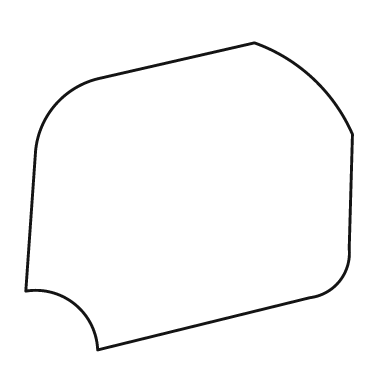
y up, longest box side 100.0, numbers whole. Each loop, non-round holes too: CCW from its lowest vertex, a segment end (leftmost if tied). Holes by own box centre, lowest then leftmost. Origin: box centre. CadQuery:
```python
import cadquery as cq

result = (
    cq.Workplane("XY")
    .moveTo(-28.0, -47.0)
    .lineTo(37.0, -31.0)
    .threePointArc((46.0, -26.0), (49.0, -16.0))
    .lineTo(50.0, 19.0)
    .threePointArc((38.0, 36.0), (20.0, 47.0))
    .lineTo(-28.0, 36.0)
    .threePointArc((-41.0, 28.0), (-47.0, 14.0))
    .lineTo(-50.0, -29.0)
    .threePointArc((-35.0, -33.0), (-28.0, -47.0))
    .close()
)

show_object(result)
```